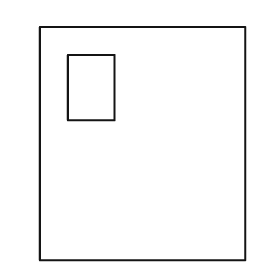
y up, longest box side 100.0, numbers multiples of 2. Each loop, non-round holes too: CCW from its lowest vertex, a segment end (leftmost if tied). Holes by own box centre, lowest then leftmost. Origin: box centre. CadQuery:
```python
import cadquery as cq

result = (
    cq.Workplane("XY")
    .moveTo(-44.0, -50.0)
    .lineTo(44.0, -50.0)
    .lineTo(44.0, 50.0)
    .lineTo(-44.0, 50.0)
    .close()
    .moveTo(-32.0, 10.0)
    .lineTo(-12.0, 10.0)
    .lineTo(-12.0, 38.0)
    .lineTo(-32.0, 38.0)
    .close()
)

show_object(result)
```